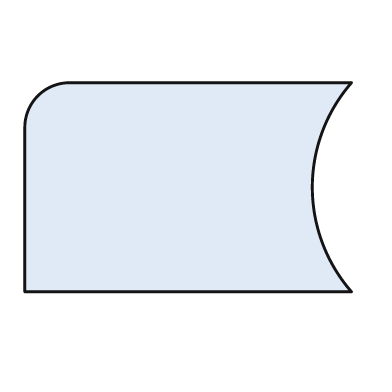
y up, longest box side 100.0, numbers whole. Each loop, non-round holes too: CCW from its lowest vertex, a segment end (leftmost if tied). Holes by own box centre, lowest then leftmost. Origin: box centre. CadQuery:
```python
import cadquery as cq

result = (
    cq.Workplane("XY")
    .moveTo(-50.0, -32.0)
    .lineTo(50.0, -32.0)
    .threePointArc((38.0, 0.0), (50.0, 32.0))
    .lineTo(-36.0, 32.0)
    .threePointArc((-46.0, 28.0), (-50.0, 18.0))
    .close()
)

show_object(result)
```